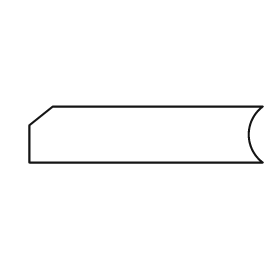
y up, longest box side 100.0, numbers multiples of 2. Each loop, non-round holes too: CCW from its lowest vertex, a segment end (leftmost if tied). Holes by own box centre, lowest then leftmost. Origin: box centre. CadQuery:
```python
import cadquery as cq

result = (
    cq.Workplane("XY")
    .moveTo(-50.0, -12.0)
    .lineTo(50.0, -12.0)
    .threePointArc((44.0, 0.0), (50.0, 12.0))
    .lineTo(-40.0, 12.0)
    .lineTo(-50.0, 4.0)
    .close()
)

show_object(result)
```